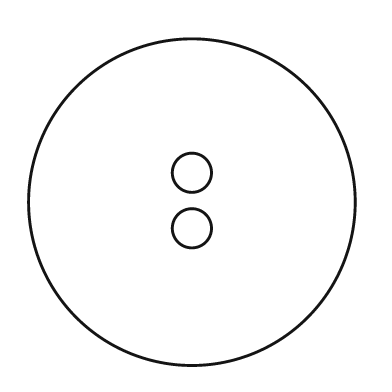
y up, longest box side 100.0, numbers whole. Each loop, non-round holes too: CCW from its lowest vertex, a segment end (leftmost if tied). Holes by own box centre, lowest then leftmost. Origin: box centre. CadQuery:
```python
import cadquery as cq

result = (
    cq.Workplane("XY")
    .moveTo(0.0, 0.0)
    .circle(50.0)
    .moveTo(0.0, -8.0)
    .circle(6.0)
    .moveTo(0.0, 9.0)
    .circle(6.0)
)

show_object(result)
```